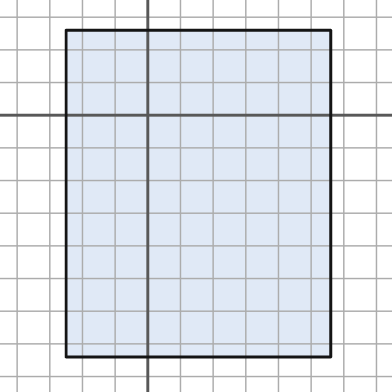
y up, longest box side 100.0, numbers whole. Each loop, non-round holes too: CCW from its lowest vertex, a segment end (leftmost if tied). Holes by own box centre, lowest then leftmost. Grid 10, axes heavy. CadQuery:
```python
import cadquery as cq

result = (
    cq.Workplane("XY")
    .moveTo(-25.0, -74.0)
    .lineTo(56.0, -74.0)
    .lineTo(56.0, 26.0)
    .lineTo(-25.0, 26.0)
    .close()
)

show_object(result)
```